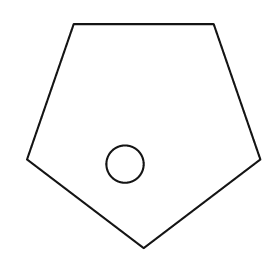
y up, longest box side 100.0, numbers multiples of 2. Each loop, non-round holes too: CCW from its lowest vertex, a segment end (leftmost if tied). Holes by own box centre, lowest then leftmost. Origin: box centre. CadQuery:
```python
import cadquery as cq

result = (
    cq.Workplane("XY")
    .moveTo(0.0, -48.0)
    .lineTo(50.0, -10.0)
    .lineTo(30.0, 48.0)
    .lineTo(-30.0, 48.0)
    .lineTo(-50.0, -10.0)
    .close()
    .moveTo(-8.0, -12.0)
    .circle(8.0)
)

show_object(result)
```